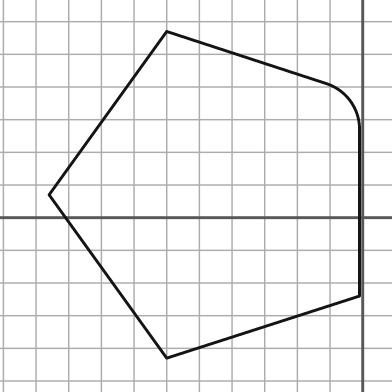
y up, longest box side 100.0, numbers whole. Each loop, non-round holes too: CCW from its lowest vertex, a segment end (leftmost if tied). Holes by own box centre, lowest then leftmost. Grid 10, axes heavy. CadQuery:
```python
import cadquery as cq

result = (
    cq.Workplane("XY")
    .moveTo(-60.0, -43.0)
    .lineTo(-1.0, -24.0)
    .lineTo(-1.0, 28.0)
    .threePointArc((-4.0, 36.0), (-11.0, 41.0))
    .lineTo(-60.0, 57.0)
    .lineTo(-96.0, 7.0)
    .close()
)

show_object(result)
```